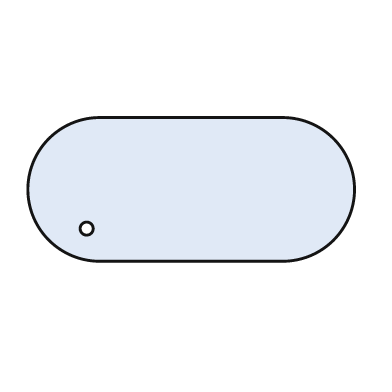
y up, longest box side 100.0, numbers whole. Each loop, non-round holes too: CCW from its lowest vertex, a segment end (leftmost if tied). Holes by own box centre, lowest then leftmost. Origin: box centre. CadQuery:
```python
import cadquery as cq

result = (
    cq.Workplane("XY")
    .moveTo(-28.0, -22.0)
    .lineTo(28.0, -22.0)
    .threePointArc((50.0, 0.0), (28.0, 22.0))
    .lineTo(-28.0, 22.0)
    .threePointArc((-50.0, 0.0), (-28.0, -22.0))
    .close()
    .moveTo(-32.0, -12.0)
    .circle(2.0)
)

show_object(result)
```